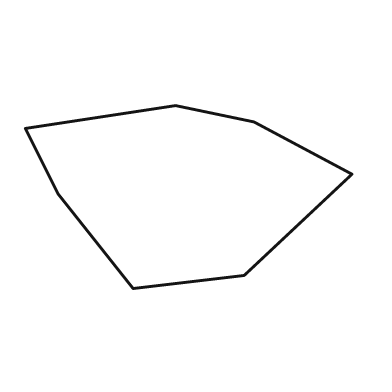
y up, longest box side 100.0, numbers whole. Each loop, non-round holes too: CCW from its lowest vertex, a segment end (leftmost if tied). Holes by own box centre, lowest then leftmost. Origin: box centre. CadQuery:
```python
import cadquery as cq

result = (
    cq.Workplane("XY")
    .moveTo(-17.0, -28.0)
    .lineTo(17.0, -24.0)
    .lineTo(50.0, 7.0)
    .lineTo(20.0, 23.0)
    .lineTo(-4.0, 28.0)
    .lineTo(-50.0, 21.0)
    .lineTo(-40.0, 1.0)
    .close()
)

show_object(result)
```